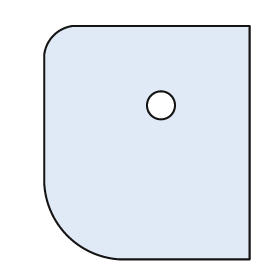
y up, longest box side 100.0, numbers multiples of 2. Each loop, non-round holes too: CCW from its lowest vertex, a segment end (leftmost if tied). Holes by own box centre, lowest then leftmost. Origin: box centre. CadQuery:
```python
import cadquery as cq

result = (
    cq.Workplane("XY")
    .moveTo(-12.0, -50.0)
    .lineTo(44.0, -50.0)
    .lineTo(44.0, 50.0)
    .lineTo(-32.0, 50.0)
    .threePointArc((-40.0, 46.0), (-44.0, 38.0))
    .lineTo(-44.0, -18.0)
    .threePointArc((-34.0, -40.0), (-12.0, -50.0))
    .close()
    .moveTo(6.0, 16.0)
    .circle(6.0)
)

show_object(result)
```